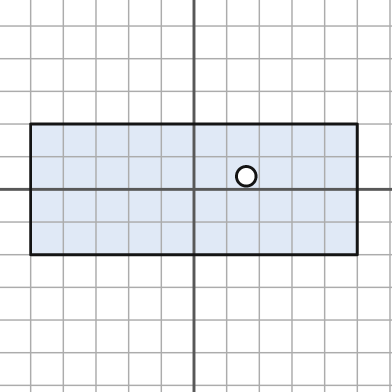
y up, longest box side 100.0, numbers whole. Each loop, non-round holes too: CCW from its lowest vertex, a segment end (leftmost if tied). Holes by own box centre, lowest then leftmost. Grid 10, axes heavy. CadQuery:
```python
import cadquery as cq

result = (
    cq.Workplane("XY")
    .moveTo(-50.0, -20.0)
    .lineTo(50.0, -20.0)
    .lineTo(50.0, 20.0)
    .lineTo(-50.0, 20.0)
    .close()
    .moveTo(16.0, 4.0)
    .circle(3.0)
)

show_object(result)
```